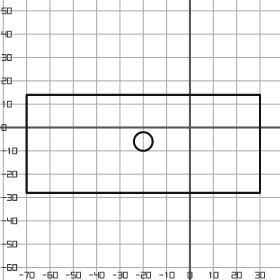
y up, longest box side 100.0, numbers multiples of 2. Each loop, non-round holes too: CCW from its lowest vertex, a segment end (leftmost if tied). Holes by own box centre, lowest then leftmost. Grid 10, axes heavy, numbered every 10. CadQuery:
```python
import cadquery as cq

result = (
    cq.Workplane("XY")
    .moveTo(-70.0, -28.0)
    .lineTo(30.0, -28.0)
    .lineTo(30.0, 14.0)
    .lineTo(-70.0, 14.0)
    .close()
    .moveTo(-20.0, -6.0)
    .circle(4.0)
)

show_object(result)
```